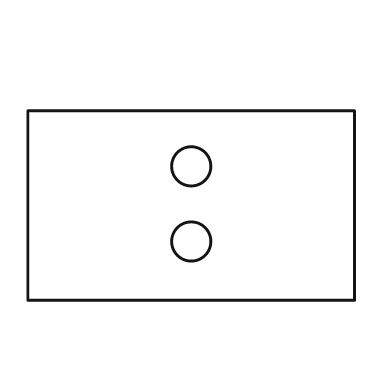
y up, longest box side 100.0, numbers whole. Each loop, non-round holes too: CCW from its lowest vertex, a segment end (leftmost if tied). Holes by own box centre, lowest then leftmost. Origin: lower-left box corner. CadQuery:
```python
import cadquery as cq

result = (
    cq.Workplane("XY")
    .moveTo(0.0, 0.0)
    .lineTo(100.0, 0.0)
    .lineTo(100.0, 58.0)
    .lineTo(0.0, 58.0)
    .close()
    .moveTo(50.0, 18.0)
    .circle(6.0)
    .moveTo(50.0, 41.0)
    .circle(6.0)
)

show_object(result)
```